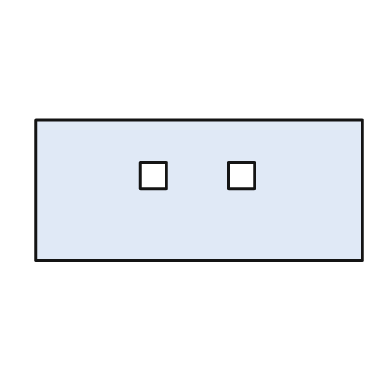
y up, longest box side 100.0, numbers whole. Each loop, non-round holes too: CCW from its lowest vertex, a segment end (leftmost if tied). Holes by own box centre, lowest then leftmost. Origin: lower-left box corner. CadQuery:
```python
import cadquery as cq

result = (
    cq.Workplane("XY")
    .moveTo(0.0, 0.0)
    .lineTo(100.0, 0.0)
    .lineTo(100.0, 43.0)
    .lineTo(0.0, 43.0)
    .close()
    .moveTo(32.0, 22.0)
    .lineTo(40.0, 22.0)
    .lineTo(40.0, 30.0)
    .lineTo(32.0, 30.0)
    .close()
    .moveTo(59.0, 22.0)
    .lineTo(67.0, 22.0)
    .lineTo(67.0, 30.0)
    .lineTo(59.0, 30.0)
    .close()
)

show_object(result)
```